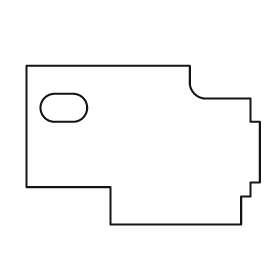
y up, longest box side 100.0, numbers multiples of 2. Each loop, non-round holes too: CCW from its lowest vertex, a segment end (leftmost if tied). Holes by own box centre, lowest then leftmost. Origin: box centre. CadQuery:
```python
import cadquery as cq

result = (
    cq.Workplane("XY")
    .moveTo(-14.0, -34.0)
    .lineTo(42.0, -34.0)
    .lineTo(42.0, -22.0)
    .lineTo(46.0, -22.0)
    .lineTo(46.0, -16.0)
    .lineTo(50.0, -16.0)
    .lineTo(50.0, 10.0)
    .lineTo(46.0, 10.0)
    .lineTo(46.0, 20.0)
    .lineTo(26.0, 20.0)
    .threePointArc((22.0, 22.0), (20.0, 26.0))
    .lineTo(20.0, 34.0)
    .lineTo(-50.0, 34.0)
    .lineTo(-50.0, -18.0)
    .lineTo(-14.0, -18.0)
    .close()
    .moveTo(-38.0, 10.0)
    .lineTo(-30.0, 10.0)
    .threePointArc((-24.0, 16.0), (-30.0, 22.0))
    .lineTo(-38.0, 22.0)
    .threePointArc((-44.0, 16.0), (-38.0, 10.0))
    .close()
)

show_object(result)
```